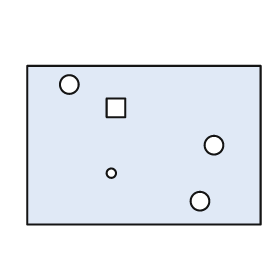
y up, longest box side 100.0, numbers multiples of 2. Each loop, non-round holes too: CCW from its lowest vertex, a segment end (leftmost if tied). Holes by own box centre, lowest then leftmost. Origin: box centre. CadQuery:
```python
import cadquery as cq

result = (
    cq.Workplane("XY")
    .moveTo(-50.0, -34.0)
    .lineTo(50.0, -34.0)
    .lineTo(50.0, 34.0)
    .lineTo(-50.0, 34.0)
    .close()
    .moveTo(24.0, -24.0)
    .circle(4.0)
    .moveTo(-14.0, -12.0)
    .circle(2.0)
    .moveTo(30.0, 0.0)
    .circle(4.0)
    .moveTo(-16.0, 12.0)
    .lineTo(-8.0, 12.0)
    .lineTo(-8.0, 20.0)
    .lineTo(-16.0, 20.0)
    .close()
    .moveTo(-32.0, 26.0)
    .circle(4.0)
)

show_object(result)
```